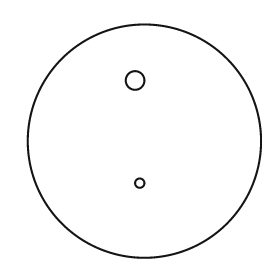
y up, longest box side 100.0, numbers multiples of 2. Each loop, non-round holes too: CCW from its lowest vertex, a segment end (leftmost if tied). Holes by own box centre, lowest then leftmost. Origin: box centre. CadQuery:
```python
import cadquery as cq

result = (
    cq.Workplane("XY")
    .moveTo(0.0, 0.0)
    .circle(50.0)
    .moveTo(-2.0, -18.0)
    .circle(2.0)
    .moveTo(-4.0, 26.0)
    .circle(4.0)
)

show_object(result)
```